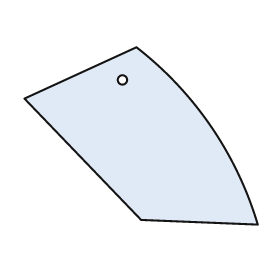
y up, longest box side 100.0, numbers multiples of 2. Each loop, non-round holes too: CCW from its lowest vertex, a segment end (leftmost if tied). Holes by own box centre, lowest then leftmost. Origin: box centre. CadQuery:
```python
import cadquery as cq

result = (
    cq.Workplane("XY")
    .moveTo(50.0, -38.0)
    .threePointArc((30.0, 4.0), (-2.0, 38.0))
    .lineTo(-50.0, 16.0)
    .lineTo(0.0, -36.0)
    .close()
    .moveTo(-8.0, 24.0)
    .circle(2.0)
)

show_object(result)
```